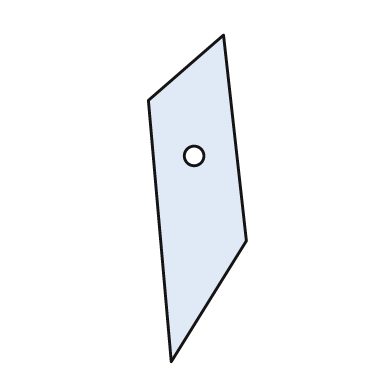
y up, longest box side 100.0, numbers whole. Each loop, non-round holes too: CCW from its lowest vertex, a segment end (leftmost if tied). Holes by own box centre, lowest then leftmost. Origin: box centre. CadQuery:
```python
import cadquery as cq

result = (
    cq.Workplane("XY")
    .moveTo(-8.0, -50.0)
    .lineTo(15.0, -13.0)
    .lineTo(8.0, 50.0)
    .lineTo(-15.0, 30.0)
    .close()
    .moveTo(-1.0, 13.0)
    .circle(3.0)
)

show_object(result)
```